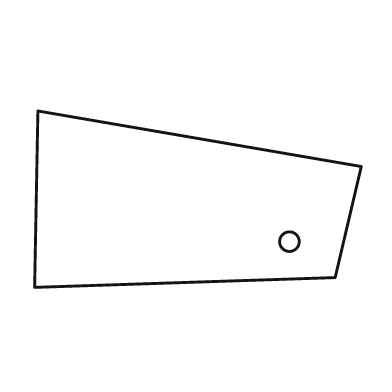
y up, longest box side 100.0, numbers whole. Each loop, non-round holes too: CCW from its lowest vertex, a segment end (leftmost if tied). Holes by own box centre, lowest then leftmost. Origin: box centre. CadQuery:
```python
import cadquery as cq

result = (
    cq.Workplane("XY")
    .moveTo(-50.0, -27.0)
    .lineTo(42.0, -24.0)
    .lineTo(50.0, 10.0)
    .lineTo(-49.0, 27.0)
    .close()
    .moveTo(28.0, -13.0)
    .circle(3.0)
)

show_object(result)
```